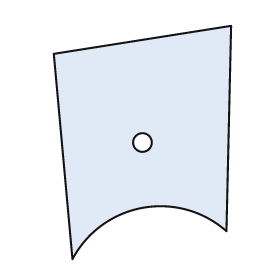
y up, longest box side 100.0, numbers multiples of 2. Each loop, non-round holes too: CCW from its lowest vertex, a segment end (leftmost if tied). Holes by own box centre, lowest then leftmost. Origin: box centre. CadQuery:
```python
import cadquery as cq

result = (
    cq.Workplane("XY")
    .moveTo(-30.0, -50.0)
    .threePointArc((0.0, -28.0), (36.0, -38.0))
    .lineTo(38.0, 50.0)
    .lineTo(-38.0, 38.0)
    .close()
    .moveTo(0.0, 0.0)
    .circle(4.0)
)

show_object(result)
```